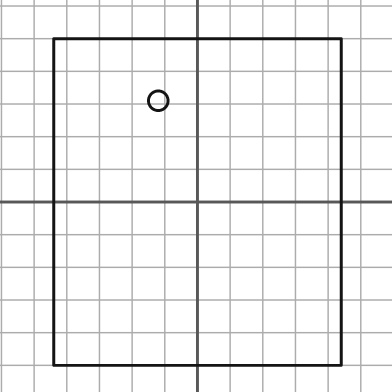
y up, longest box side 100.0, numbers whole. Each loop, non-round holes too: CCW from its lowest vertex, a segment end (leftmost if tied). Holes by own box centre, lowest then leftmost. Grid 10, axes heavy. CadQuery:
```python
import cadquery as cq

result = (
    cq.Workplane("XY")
    .moveTo(-44.0, -50.0)
    .lineTo(44.0, -50.0)
    .lineTo(44.0, 50.0)
    .lineTo(-44.0, 50.0)
    .close()
    .moveTo(-12.0, 31.0)
    .circle(3.0)
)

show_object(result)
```